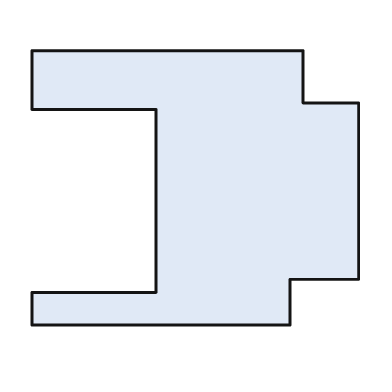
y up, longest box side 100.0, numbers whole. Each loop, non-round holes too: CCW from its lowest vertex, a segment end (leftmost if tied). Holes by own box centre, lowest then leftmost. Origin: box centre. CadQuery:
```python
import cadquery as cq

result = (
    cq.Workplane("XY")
    .moveTo(-50.0, -42.0)
    .lineTo(29.0, -42.0)
    .lineTo(29.0, -28.0)
    .lineTo(50.0, -28.0)
    .lineTo(50.0, 26.0)
    .lineTo(33.0, 26.0)
    .lineTo(33.0, 42.0)
    .lineTo(-50.0, 42.0)
    .lineTo(-50.0, 24.0)
    .lineTo(-12.0, 24.0)
    .lineTo(-12.0, -32.0)
    .lineTo(-50.0, -32.0)
    .close()
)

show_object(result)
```